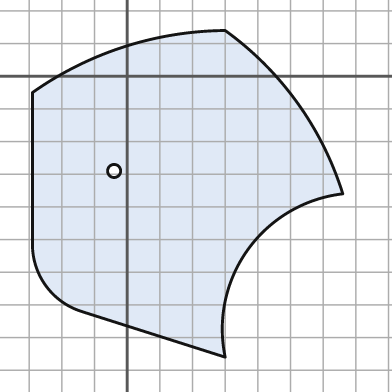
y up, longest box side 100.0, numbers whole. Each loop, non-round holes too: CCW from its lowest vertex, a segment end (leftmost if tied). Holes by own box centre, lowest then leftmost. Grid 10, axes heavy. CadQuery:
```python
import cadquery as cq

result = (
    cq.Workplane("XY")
    .moveTo(30.0, -86.0)
    .threePointArc((37.0, -53.0), (66.0, -36.0))
    .threePointArc((52.0, -8.0), (30.0, 14.0))
    .threePointArc((-1.0, 9.0), (-29.0, -5.0))
    .lineTo(-29.0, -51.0)
    .threePointArc((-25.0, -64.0), (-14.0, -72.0))
    .close()
    .moveTo(-4.0, -29.0)
    .circle(2.0)
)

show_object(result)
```